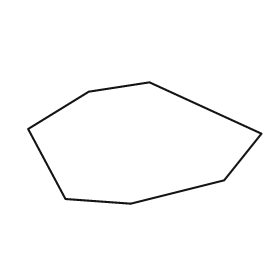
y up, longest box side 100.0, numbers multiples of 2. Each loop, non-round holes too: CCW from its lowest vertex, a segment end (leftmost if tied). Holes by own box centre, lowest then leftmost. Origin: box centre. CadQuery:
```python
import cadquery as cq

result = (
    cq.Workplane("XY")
    .moveTo(-6.0, -26.0)
    .lineTo(34.0, -16.0)
    .lineTo(50.0, 4.0)
    .lineTo(2.0, 26.0)
    .lineTo(-24.0, 22.0)
    .lineTo(-50.0, 6.0)
    .lineTo(-34.0, -24.0)
    .close()
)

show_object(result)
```